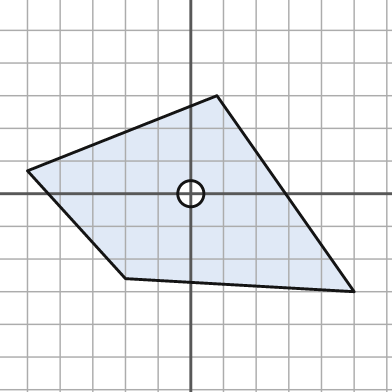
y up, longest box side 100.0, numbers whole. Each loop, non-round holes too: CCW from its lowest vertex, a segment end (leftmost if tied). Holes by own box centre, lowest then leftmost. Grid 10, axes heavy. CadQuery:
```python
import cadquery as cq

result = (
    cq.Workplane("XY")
    .moveTo(50.0, -30.0)
    .lineTo(8.0, 30.0)
    .lineTo(-50.0, 7.0)
    .lineTo(-20.0, -26.0)
    .close()
    .moveTo(0.0, 0.0)
    .circle(4.0)
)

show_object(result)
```